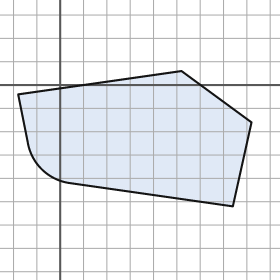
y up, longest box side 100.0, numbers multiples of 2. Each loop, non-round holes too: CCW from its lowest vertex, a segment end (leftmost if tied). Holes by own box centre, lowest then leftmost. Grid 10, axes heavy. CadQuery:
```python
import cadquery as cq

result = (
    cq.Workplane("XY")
    .moveTo(74.0, -52.0)
    .lineTo(82.0, -16.0)
    .lineTo(52.0, 6.0)
    .lineTo(-18.0, -4.0)
    .lineTo(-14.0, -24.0)
    .threePointArc((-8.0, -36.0), (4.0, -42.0))
    .close()
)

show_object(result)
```